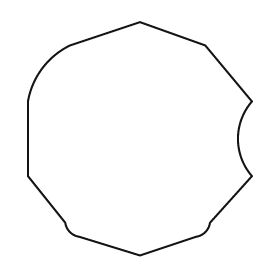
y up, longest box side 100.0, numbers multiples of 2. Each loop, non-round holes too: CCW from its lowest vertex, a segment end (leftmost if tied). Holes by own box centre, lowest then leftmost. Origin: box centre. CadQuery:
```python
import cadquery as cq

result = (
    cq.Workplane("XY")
    .moveTo(0.0, -50.0)
    .lineTo(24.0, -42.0)
    .threePointArc((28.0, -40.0), (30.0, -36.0))
    .lineTo(48.0, -16.0)
    .threePointArc((42.0, 0.0), (48.0, 16.0))
    .lineTo(28.0, 40.0)
    .lineTo(0.0, 50.0)
    .lineTo(-30.0, 40.0)
    .threePointArc((-42.0, 30.0), (-48.0, 16.0))
    .lineTo(-48.0, -16.0)
    .lineTo(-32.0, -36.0)
    .threePointArc((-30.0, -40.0), (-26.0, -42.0))
    .close()
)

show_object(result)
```